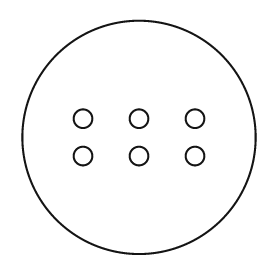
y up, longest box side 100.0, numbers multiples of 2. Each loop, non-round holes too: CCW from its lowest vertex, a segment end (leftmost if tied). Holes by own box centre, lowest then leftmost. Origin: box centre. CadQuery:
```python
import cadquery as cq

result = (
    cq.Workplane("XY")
    .moveTo(0.0, 0.0)
    .circle(50.0)
    .moveTo(-24.0, -8.0)
    .circle(4.0)
    .moveTo(0.0, -8.0)
    .circle(4.0)
    .moveTo(24.0, -8.0)
    .circle(4.0)
    .moveTo(-24.0, 8.0)
    .circle(4.0)
    .moveTo(0.0, 8.0)
    .circle(4.0)
    .moveTo(24.0, 8.0)
    .circle(4.0)
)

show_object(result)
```